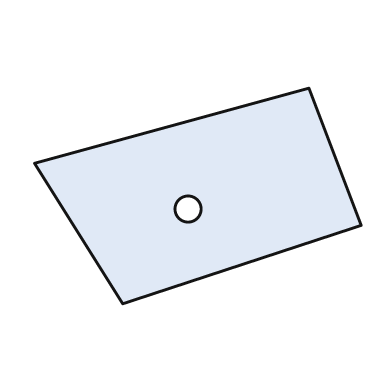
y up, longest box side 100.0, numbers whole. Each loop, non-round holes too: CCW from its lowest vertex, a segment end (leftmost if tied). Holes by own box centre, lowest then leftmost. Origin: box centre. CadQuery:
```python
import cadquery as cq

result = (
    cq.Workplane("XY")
    .moveTo(-23.0, -33.0)
    .lineTo(50.0, -9.0)
    .lineTo(34.0, 33.0)
    .lineTo(-50.0, 10.0)
    .close()
    .moveTo(-3.0, -4.0)
    .circle(4.0)
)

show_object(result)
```